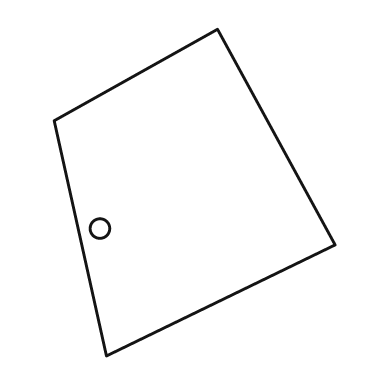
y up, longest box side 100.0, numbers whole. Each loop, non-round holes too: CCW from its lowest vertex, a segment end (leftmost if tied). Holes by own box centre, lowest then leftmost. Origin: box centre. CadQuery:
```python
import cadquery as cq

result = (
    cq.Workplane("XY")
    .moveTo(-27.0, -50.0)
    .lineTo(43.0, -16.0)
    .lineTo(7.0, 50.0)
    .lineTo(-43.0, 22.0)
    .close()
    .moveTo(-29.0, -11.0)
    .circle(3.0)
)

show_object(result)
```